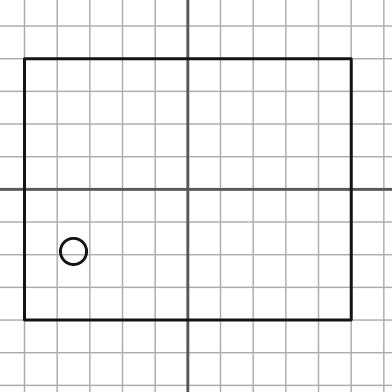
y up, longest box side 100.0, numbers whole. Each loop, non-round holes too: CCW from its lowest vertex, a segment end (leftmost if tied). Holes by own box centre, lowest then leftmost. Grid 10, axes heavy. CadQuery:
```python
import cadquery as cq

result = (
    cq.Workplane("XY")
    .moveTo(-50.0, -40.0)
    .lineTo(50.0, -40.0)
    .lineTo(50.0, 40.0)
    .lineTo(-50.0, 40.0)
    .close()
    .moveTo(-35.0, -19.0)
    .circle(4.0)
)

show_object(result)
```